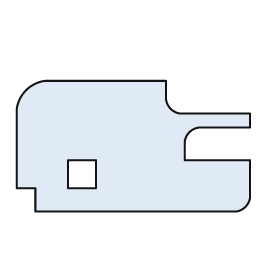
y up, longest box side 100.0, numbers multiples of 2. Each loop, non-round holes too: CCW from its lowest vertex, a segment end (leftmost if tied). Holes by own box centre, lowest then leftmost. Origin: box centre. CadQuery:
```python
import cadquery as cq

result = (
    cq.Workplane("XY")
    .moveTo(-42.0, -28.0)
    .lineTo(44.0, -28.0)
    .threePointArc((48.0, -26.0), (50.0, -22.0))
    .lineTo(50.0, -6.0)
    .lineTo(22.0, -6.0)
    .lineTo(22.0, 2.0)
    .threePointArc((24.0, 6.0), (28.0, 8.0))
    .lineTo(50.0, 8.0)
    .lineTo(50.0, 14.0)
    .lineTo(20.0, 14.0)
    .threePointArc((16.0, 16.0), (14.0, 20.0))
    .lineTo(14.0, 28.0)
    .lineTo(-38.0, 28.0)
    .threePointArc((-46.0, 24.0), (-50.0, 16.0))
    .lineTo(-50.0, -18.0)
    .lineTo(-42.0, -18.0)
    .close()
    .moveTo(-28.0, -18.0)
    .lineTo(-16.0, -18.0)
    .lineTo(-16.0, -6.0)
    .lineTo(-28.0, -6.0)
    .close()
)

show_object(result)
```